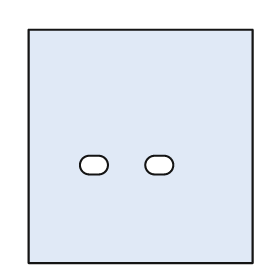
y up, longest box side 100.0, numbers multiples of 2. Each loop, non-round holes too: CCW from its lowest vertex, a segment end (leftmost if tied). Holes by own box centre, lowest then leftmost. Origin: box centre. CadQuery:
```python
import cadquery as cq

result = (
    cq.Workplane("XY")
    .moveTo(-48.0, -50.0)
    .lineTo(48.0, -50.0)
    .lineTo(48.0, 50.0)
    .lineTo(-48.0, 50.0)
    .close()
    .moveTo(-22.0, -12.0)
    .lineTo(-18.0, -12.0)
    .threePointArc((-14.0, -8.0), (-18.0, -4.0))
    .lineTo(-22.0, -4.0)
    .threePointArc((-26.0, -8.0), (-22.0, -12.0))
    .close()
    .moveTo(6.0, -12.0)
    .lineTo(10.0, -12.0)
    .threePointArc((14.0, -8.0), (10.0, -4.0))
    .lineTo(6.0, -4.0)
    .threePointArc((2.0, -8.0), (6.0, -12.0))
    .close()
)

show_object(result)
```